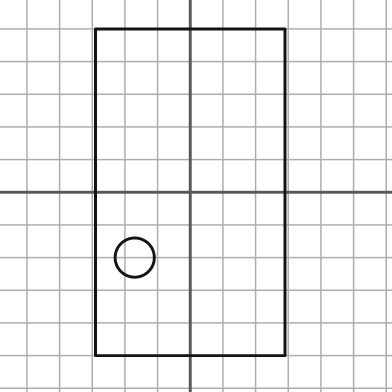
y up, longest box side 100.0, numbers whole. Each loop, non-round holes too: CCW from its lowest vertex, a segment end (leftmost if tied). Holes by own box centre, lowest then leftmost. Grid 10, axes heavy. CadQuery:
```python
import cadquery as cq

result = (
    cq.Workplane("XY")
    .moveTo(-29.0, -50.0)
    .lineTo(29.0, -50.0)
    .lineTo(29.0, 50.0)
    .lineTo(-29.0, 50.0)
    .close()
    .moveTo(-17.0, -20.0)
    .circle(6.0)
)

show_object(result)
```